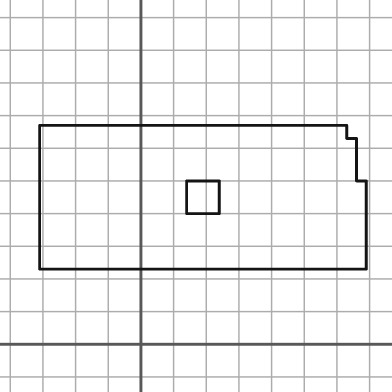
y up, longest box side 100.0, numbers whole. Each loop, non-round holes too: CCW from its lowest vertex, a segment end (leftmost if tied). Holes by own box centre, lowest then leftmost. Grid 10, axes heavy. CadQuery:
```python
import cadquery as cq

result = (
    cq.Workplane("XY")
    .moveTo(-31.0, 23.0)
    .lineTo(69.0, 23.0)
    .lineTo(69.0, 50.0)
    .lineTo(66.0, 50.0)
    .lineTo(66.0, 63.0)
    .lineTo(63.0, 63.0)
    .lineTo(63.0, 67.0)
    .lineTo(-31.0, 67.0)
    .close()
    .moveTo(14.0, 40.0)
    .lineTo(24.0, 40.0)
    .lineTo(24.0, 50.0)
    .lineTo(14.0, 50.0)
    .close()
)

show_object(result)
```